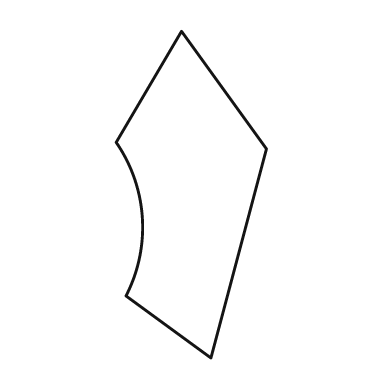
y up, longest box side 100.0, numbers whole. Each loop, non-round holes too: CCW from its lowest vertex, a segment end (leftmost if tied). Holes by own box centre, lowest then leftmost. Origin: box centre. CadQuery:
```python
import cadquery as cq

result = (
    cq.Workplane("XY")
    .moveTo(6.0, -50.0)
    .lineTo(23.0, 14.0)
    .lineTo(-3.0, 50.0)
    .lineTo(-23.0, 16.0)
    .threePointArc((-15.0, -7.0), (-20.0, -31.0))
    .close()
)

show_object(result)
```